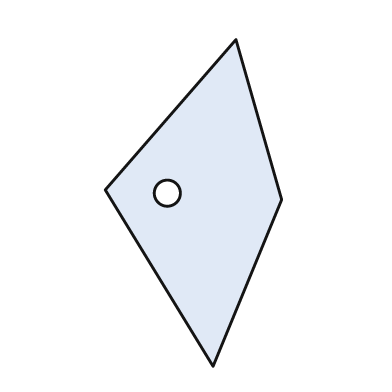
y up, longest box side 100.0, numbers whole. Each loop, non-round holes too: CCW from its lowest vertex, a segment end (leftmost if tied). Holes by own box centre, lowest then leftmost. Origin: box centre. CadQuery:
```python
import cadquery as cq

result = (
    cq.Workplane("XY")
    .moveTo(6.0, -50.0)
    .lineTo(27.0, 1.0)
    .lineTo(13.0, 50.0)
    .lineTo(-27.0, 4.0)
    .close()
    .moveTo(-8.0, 3.0)
    .circle(4.0)
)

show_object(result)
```